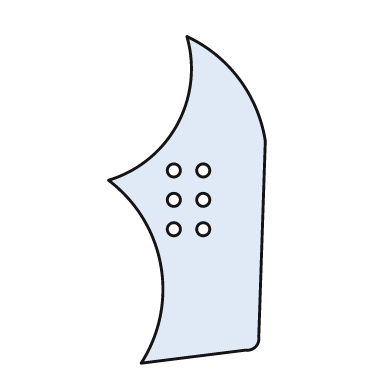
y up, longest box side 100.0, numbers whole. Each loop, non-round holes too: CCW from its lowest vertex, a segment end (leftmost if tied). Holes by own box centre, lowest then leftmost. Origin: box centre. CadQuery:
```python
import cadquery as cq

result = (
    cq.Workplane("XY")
    .moveTo(-14.0, -50.0)
    .lineTo(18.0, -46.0)
    .threePointArc((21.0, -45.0), (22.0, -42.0))
    .lineTo(24.0, 18.0)
    .threePointArc((16.0, 37.0), (0.0, 50.0))
    .threePointArc((-3.0, 23.0), (-24.0, 6.0))
    .threePointArc((-8.0, -20.0), (-14.0, -50.0))
    .close()
    .moveTo(-4.0, -9.0)
    .circle(2.0)
    .moveTo(5.0, -9.0)
    .circle(2.0)
    .moveTo(-4.0, 0.0)
    .circle(2.0)
    .moveTo(5.0, 0.0)
    .circle(2.0)
    .moveTo(-4.0, 9.0)
    .circle(2.0)
    .moveTo(5.0, 9.0)
    .circle(2.0)
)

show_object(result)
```